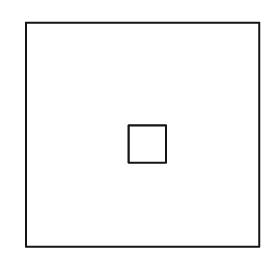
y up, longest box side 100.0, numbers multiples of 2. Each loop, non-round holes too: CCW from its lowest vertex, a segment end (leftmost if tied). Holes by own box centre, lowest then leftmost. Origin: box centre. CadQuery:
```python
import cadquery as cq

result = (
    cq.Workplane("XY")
    .moveTo(-50.0, -48.0)
    .lineTo(50.0, -48.0)
    .lineTo(50.0, 48.0)
    .lineTo(-50.0, 48.0)
    .close()
    .moveTo(-6.0, -12.0)
    .lineTo(10.0, -12.0)
    .lineTo(10.0, 4.0)
    .lineTo(-6.0, 4.0)
    .close()
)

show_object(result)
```